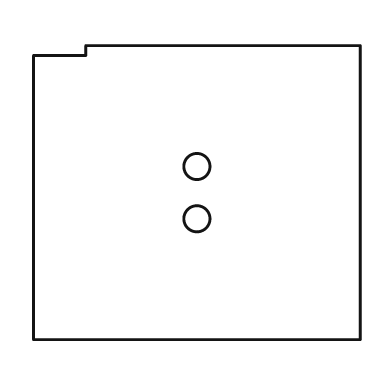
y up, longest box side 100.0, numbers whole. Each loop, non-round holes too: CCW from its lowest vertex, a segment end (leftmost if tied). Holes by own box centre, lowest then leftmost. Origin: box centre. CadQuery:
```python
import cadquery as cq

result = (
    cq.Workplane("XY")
    .moveTo(-50.0, -45.0)
    .lineTo(50.0, -45.0)
    .lineTo(50.0, 45.0)
    .lineTo(-34.0, 45.0)
    .lineTo(-34.0, 42.0)
    .lineTo(-50.0, 42.0)
    .close()
    .moveTo(0.0, -8.0)
    .circle(4.0)
    .moveTo(0.0, 8.0)
    .circle(4.0)
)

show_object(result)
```